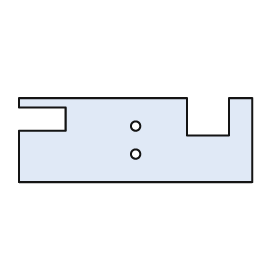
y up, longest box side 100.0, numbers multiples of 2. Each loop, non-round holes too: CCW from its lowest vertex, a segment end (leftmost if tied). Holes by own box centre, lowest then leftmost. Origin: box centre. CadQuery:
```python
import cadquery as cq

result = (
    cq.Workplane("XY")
    .moveTo(-50.0, -18.0)
    .lineTo(50.0, -18.0)
    .lineTo(50.0, 18.0)
    .lineTo(40.0, 18.0)
    .lineTo(40.0, 2.0)
    .lineTo(22.0, 2.0)
    .lineTo(22.0, 18.0)
    .lineTo(-50.0, 18.0)
    .lineTo(-50.0, 14.0)
    .lineTo(-30.0, 14.0)
    .lineTo(-30.0, 4.0)
    .lineTo(-50.0, 4.0)
    .close()
    .moveTo(0.0, -6.0)
    .circle(2.0)
    .moveTo(0.0, 6.0)
    .circle(2.0)
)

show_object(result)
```